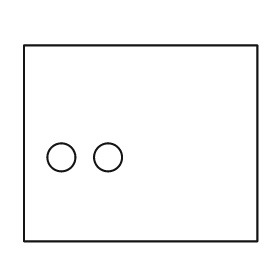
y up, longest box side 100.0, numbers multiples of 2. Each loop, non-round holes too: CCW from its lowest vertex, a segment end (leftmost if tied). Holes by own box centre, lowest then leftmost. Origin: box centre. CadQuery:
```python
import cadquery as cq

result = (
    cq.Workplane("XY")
    .moveTo(-50.0, -42.0)
    .lineTo(50.0, -42.0)
    .lineTo(50.0, 42.0)
    .lineTo(-50.0, 42.0)
    .close()
    .moveTo(-34.0, -6.0)
    .circle(6.0)
    .moveTo(-14.0, -6.0)
    .circle(6.0)
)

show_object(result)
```